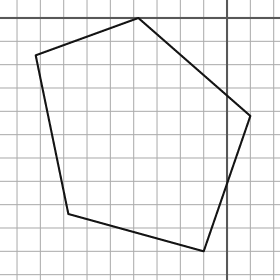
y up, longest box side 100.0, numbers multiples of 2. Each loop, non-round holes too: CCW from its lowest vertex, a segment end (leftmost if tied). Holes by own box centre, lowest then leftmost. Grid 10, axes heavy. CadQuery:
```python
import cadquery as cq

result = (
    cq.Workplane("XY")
    .moveTo(-10.0, -100.0)
    .lineTo(10.0, -42.0)
    .lineTo(-38.0, 0.0)
    .lineTo(-82.0, -16.0)
    .lineTo(-68.0, -84.0)
    .close()
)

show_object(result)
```